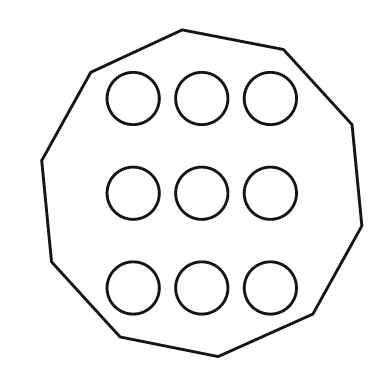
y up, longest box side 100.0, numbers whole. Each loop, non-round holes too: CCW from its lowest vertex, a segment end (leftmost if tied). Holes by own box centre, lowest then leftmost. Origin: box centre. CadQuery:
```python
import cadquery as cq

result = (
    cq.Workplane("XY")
    .moveTo(5.0, -50.0)
    .lineTo(34.0, -37.0)
    .lineTo(49.0, -10.0)
    .lineTo(46.0, 21.0)
    .lineTo(25.0, 44.0)
    .lineTo(-6.0, 50.0)
    .lineTo(-34.0, 37.0)
    .lineTo(-49.0, 10.0)
    .lineTo(-46.0, -21.0)
    .lineTo(-25.0, -44.0)
    .close()
    .moveTo(-21.0, -29.0)
    .circle(8.0)
    .moveTo(0.0, -29.0)
    .circle(8.0)
    .moveTo(21.0, -29.0)
    .circle(8.0)
    .moveTo(-21.0, 0.0)
    .circle(8.0)
    .moveTo(0.0, 0.0)
    .circle(8.0)
    .moveTo(21.0, 0.0)
    .circle(8.0)
    .moveTo(-21.0, 29.0)
    .circle(8.0)
    .moveTo(0.0, 29.0)
    .circle(8.0)
    .moveTo(21.0, 29.0)
    .circle(8.0)
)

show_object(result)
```